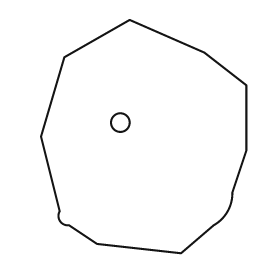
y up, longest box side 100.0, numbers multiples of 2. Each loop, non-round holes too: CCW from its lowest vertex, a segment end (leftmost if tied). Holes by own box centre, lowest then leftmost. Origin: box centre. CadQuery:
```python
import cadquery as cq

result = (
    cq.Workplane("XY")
    .moveTo(16.0, -50.0)
    .lineTo(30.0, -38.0)
    .threePointArc((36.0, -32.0), (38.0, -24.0))
    .lineTo(44.0, -6.0)
    .lineTo(44.0, 22.0)
    .lineTo(26.0, 36.0)
    .lineTo(-6.0, 50.0)
    .lineTo(-34.0, 34.0)
    .lineTo(-44.0, 0.0)
    .lineTo(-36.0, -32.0)
    .threePointArc((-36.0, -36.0), (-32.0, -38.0))
    .lineTo(-20.0, -46.0)
    .close()
    .moveTo(-10.0, 6.0)
    .circle(4.0)
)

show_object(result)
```